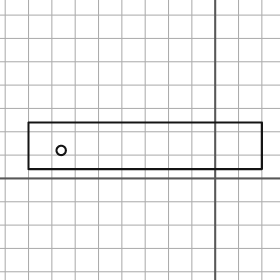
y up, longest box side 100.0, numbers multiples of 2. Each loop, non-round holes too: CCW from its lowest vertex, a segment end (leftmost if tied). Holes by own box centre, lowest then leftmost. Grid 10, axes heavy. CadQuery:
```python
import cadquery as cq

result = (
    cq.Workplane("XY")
    .moveTo(-80.0, 4.0)
    .lineTo(20.0, 4.0)
    .lineTo(20.0, 24.0)
    .lineTo(-80.0, 24.0)
    .close()
    .moveTo(-66.0, 12.0)
    .circle(2.0)
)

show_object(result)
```